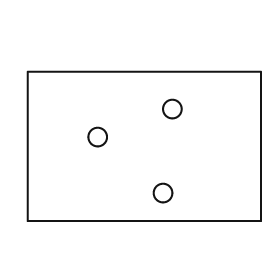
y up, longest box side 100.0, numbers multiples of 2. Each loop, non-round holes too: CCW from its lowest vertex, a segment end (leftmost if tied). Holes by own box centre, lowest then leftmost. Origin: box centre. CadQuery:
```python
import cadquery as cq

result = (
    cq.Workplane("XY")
    .moveTo(-50.0, -32.0)
    .lineTo(50.0, -32.0)
    .lineTo(50.0, 32.0)
    .lineTo(-50.0, 32.0)
    .close()
    .moveTo(8.0, -20.0)
    .circle(4.0)
    .moveTo(-20.0, 4.0)
    .circle(4.0)
    .moveTo(12.0, 16.0)
    .circle(4.0)
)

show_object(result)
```